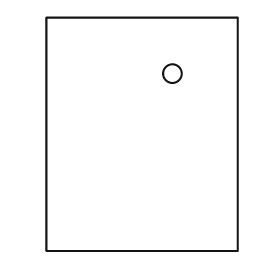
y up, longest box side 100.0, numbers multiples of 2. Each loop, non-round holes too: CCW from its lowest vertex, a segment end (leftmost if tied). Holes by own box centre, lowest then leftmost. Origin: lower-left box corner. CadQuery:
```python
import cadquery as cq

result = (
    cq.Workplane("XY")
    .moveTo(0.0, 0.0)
    .lineTo(82.0, 0.0)
    .lineTo(82.0, 100.0)
    .lineTo(0.0, 100.0)
    .close()
    .moveTo(54.0, 76.0)
    .circle(4.0)
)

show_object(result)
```